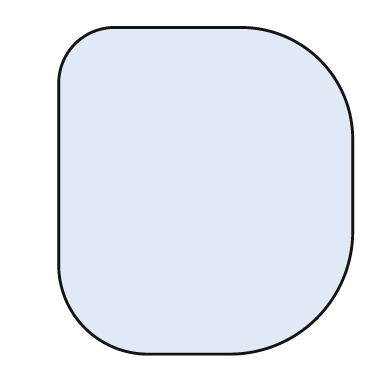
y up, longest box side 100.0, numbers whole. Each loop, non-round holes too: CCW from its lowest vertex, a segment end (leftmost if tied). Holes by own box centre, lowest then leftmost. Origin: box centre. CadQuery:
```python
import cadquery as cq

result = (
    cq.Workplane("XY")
    .moveTo(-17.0, -50.0)
    .lineTo(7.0, -50.0)
    .threePointArc((34.0, -39.0), (45.0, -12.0))
    .lineTo(45.0, 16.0)
    .threePointArc((35.0, 40.0), (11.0, 50.0))
    .lineTo(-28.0, 50.0)
    .threePointArc((-40.0, 45.0), (-45.0, 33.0))
    .lineTo(-45.0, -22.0)
    .threePointArc((-37.0, -42.0), (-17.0, -50.0))
    .close()
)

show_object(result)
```